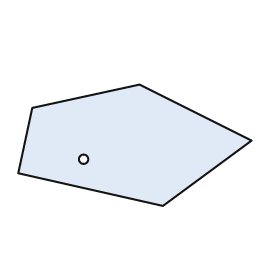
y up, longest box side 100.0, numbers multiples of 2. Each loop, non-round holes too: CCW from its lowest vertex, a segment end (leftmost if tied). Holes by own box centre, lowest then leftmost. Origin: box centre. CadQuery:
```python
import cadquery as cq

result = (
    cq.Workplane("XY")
    .moveTo(12.0, -26.0)
    .lineTo(50.0, 2.0)
    .lineTo(2.0, 26.0)
    .lineTo(-44.0, 16.0)
    .lineTo(-50.0, -12.0)
    .close()
    .moveTo(-22.0, -6.0)
    .circle(2.0)
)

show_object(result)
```